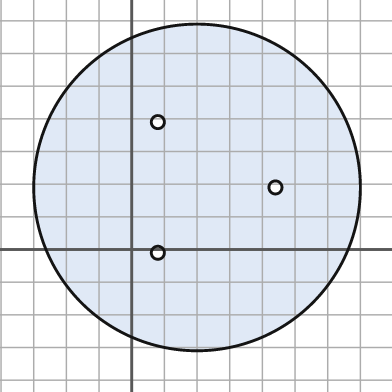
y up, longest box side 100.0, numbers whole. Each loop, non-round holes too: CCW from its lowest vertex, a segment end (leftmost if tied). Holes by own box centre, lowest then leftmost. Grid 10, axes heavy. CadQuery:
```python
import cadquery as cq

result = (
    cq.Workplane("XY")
    .moveTo(20.0, 19.0)
    .circle(50.0)
    .moveTo(8.0, -1.0)
    .circle(2.0)
    .moveTo(44.0, 19.0)
    .circle(2.0)
    .moveTo(8.0, 39.0)
    .circle(2.0)
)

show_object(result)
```